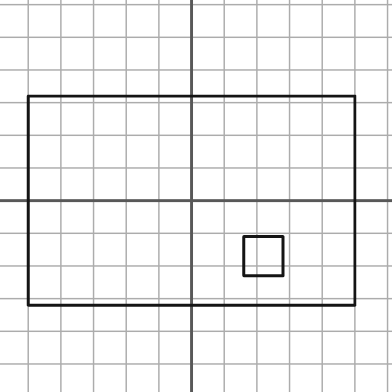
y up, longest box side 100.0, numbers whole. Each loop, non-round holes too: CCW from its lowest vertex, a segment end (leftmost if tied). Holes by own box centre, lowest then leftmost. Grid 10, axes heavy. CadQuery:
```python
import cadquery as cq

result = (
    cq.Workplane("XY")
    .moveTo(-50.0, -32.0)
    .lineTo(50.0, -32.0)
    .lineTo(50.0, 32.0)
    .lineTo(-50.0, 32.0)
    .close()
    .moveTo(16.0, -23.0)
    .lineTo(28.0, -23.0)
    .lineTo(28.0, -11.0)
    .lineTo(16.0, -11.0)
    .close()
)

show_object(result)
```